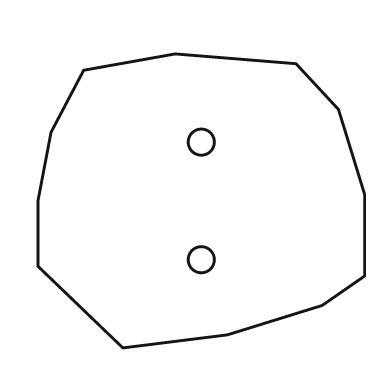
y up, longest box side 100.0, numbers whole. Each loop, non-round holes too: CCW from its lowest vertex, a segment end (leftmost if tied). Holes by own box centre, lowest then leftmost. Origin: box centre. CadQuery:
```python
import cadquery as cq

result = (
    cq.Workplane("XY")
    .moveTo(-24.0, -45.0)
    .lineTo(8.0, -41.0)
    .lineTo(37.0, -32.0)
    .lineTo(50.0, -23.0)
    .lineTo(50.0, 2.0)
    .lineTo(42.0, 28.0)
    .lineTo(29.0, 42.0)
    .lineTo(-8.0, 45.0)
    .lineTo(-36.0, 40.0)
    .lineTo(-46.0, 21.0)
    .lineTo(-50.0, 0.0)
    .lineTo(-50.0, -20.0)
    .close()
    .moveTo(0.0, -18.0)
    .circle(4.0)
    .moveTo(0.0, 18.0)
    .circle(4.0)
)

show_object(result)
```